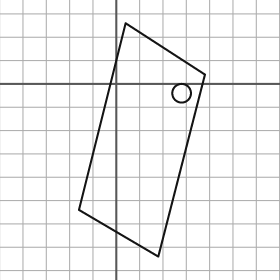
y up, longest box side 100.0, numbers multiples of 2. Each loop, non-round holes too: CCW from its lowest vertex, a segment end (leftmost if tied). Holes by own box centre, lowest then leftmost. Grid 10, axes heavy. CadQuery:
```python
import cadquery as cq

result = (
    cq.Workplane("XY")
    .moveTo(18.0, -74.0)
    .lineTo(38.0, 4.0)
    .lineTo(4.0, 26.0)
    .lineTo(-16.0, -54.0)
    .close()
    .moveTo(28.0, -4.0)
    .circle(4.0)
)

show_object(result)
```